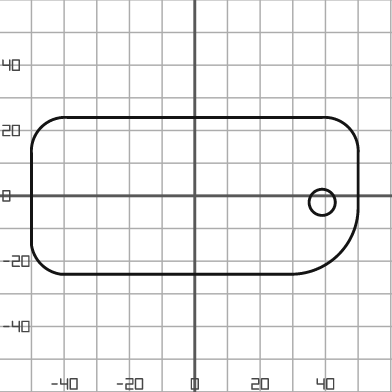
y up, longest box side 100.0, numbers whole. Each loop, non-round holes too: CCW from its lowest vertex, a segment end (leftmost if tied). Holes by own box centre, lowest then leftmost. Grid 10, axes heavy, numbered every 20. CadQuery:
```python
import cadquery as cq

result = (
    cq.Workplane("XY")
    .moveTo(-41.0, -24.0)
    .lineTo(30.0, -24.0)
    .threePointArc((44.0, -18.0), (50.0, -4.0))
    .lineTo(50.0, 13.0)
    .threePointArc((47.0, 21.0), (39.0, 24.0))
    .lineTo(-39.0, 24.0)
    .threePointArc((-47.0, 21.0), (-50.0, 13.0))
    .lineTo(-50.0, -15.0)
    .threePointArc((-47.0, -21.0), (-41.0, -24.0))
    .close()
    .moveTo(39.0, -2.0)
    .circle(4.0)
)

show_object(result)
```